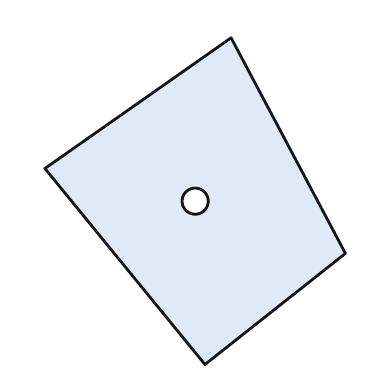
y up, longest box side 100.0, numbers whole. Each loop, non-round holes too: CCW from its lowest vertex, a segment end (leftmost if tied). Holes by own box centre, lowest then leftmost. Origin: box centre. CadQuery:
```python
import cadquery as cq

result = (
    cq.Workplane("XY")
    .moveTo(3.0, -50.0)
    .lineTo(46.0, -16.0)
    .lineTo(11.0, 50.0)
    .lineTo(-46.0, 10.0)
    .close()
    .moveTo(0.0, 0.0)
    .circle(4.0)
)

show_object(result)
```